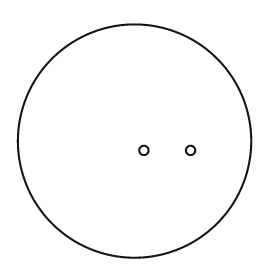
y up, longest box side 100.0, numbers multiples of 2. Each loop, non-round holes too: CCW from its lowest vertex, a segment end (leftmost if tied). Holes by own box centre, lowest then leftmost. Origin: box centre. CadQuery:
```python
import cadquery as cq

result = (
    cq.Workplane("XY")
    .moveTo(0.0, 0.0)
    .circle(50.0)
    .moveTo(4.0, -4.0)
    .circle(2.0)
    .moveTo(24.0, -4.0)
    .circle(2.0)
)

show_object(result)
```